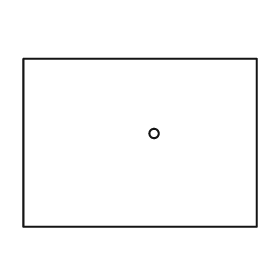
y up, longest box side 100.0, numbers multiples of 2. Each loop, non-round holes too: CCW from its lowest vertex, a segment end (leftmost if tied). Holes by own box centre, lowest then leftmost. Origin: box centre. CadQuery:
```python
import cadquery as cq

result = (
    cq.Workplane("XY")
    .moveTo(-50.0, -36.0)
    .lineTo(50.0, -36.0)
    .lineTo(50.0, 36.0)
    .lineTo(-50.0, 36.0)
    .close()
    .moveTo(6.0, 4.0)
    .circle(2.0)
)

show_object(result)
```